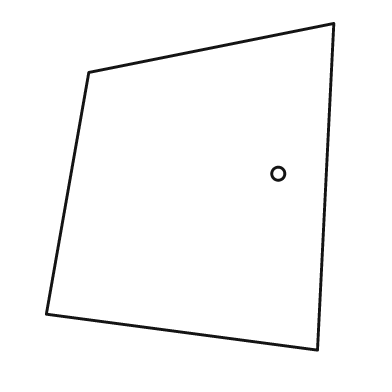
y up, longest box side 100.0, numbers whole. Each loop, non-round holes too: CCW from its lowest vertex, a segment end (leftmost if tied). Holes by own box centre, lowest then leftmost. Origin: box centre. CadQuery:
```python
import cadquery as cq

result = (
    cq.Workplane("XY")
    .moveTo(39.0, -50.0)
    .lineTo(44.0, 50.0)
    .lineTo(-31.0, 35.0)
    .lineTo(-44.0, -39.0)
    .close()
    .moveTo(27.0, 4.0)
    .circle(2.0)
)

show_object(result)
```